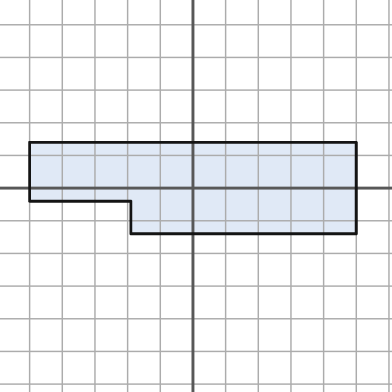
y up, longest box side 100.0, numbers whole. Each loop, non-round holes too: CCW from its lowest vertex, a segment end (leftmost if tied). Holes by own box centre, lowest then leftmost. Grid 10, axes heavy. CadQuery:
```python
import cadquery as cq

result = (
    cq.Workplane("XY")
    .moveTo(-19.0, -14.0)
    .lineTo(50.0, -14.0)
    .lineTo(50.0, 14.0)
    .lineTo(-50.0, 14.0)
    .lineTo(-50.0, -4.0)
    .lineTo(-19.0, -4.0)
    .close()
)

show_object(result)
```